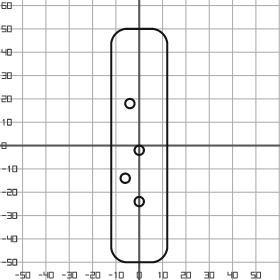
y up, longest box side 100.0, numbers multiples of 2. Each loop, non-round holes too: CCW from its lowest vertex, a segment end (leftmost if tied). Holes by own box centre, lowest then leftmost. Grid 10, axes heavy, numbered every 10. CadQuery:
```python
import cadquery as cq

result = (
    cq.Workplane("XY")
    .moveTo(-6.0, -50.0)
    .lineTo(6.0, -50.0)
    .threePointArc((10.0, -48.0), (12.0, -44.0))
    .lineTo(12.0, 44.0)
    .threePointArc((10.0, 48.0), (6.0, 50.0))
    .lineTo(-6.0, 50.0)
    .threePointArc((-10.0, 48.0), (-12.0, 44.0))
    .lineTo(-12.0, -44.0)
    .threePointArc((-10.0, -48.0), (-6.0, -50.0))
    .close()
    .moveTo(0.0, -24.0)
    .circle(2.0)
    .moveTo(-6.0, -14.0)
    .circle(2.0)
    .moveTo(0.0, -2.0)
    .circle(2.0)
    .moveTo(-4.0, 18.0)
    .circle(2.0)
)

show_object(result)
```